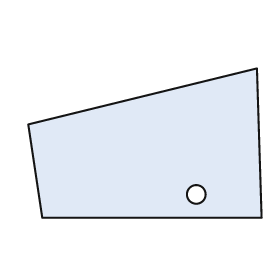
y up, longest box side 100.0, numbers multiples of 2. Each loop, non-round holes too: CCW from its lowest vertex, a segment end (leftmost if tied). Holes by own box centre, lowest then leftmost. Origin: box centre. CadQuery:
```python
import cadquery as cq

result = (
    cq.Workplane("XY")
    .moveTo(-44.0, -32.0)
    .lineTo(50.0, -32.0)
    .lineTo(48.0, 32.0)
    .lineTo(-50.0, 8.0)
    .close()
    .moveTo(22.0, -22.0)
    .circle(4.0)
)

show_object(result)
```